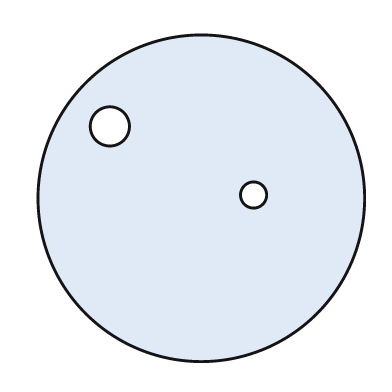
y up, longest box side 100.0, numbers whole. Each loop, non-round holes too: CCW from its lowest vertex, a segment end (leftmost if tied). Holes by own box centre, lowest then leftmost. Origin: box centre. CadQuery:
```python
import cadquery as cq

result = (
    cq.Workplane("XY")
    .moveTo(0.0, 0.0)
    .circle(50.0)
    .moveTo(16.0, 1.0)
    .circle(4.0)
    .moveTo(-28.0, 22.0)
    .circle(6.0)
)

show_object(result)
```